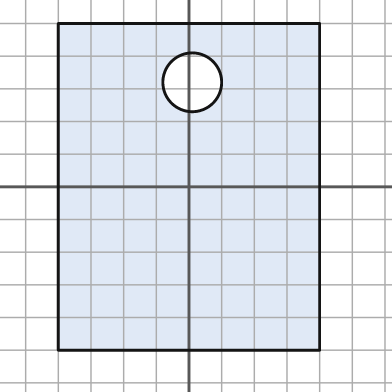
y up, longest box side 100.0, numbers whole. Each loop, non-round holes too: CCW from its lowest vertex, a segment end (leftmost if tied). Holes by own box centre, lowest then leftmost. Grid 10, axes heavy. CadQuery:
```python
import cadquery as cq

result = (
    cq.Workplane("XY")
    .moveTo(-40.0, -50.0)
    .lineTo(40.0, -50.0)
    .lineTo(40.0, 50.0)
    .lineTo(-40.0, 50.0)
    .close()
    .moveTo(1.0, 32.0)
    .circle(9.0)
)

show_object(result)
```